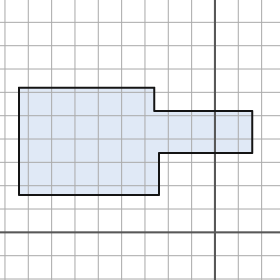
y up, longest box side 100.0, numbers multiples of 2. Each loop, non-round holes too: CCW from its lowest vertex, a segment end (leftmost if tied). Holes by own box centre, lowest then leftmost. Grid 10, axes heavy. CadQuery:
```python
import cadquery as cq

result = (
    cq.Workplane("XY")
    .moveTo(-84.0, 16.0)
    .lineTo(-24.0, 16.0)
    .lineTo(-24.0, 34.0)
    .lineTo(16.0, 34.0)
    .lineTo(16.0, 52.0)
    .lineTo(-26.0, 52.0)
    .lineTo(-26.0, 62.0)
    .lineTo(-84.0, 62.0)
    .close()
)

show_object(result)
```